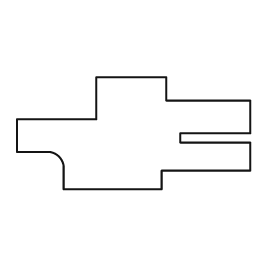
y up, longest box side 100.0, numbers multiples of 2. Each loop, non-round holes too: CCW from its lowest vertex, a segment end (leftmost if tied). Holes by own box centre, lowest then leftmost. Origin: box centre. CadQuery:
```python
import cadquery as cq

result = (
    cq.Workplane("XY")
    .moveTo(-30.0, -24.0)
    .lineTo(12.0, -24.0)
    .lineTo(12.0, -16.0)
    .lineTo(50.0, -16.0)
    .lineTo(50.0, -4.0)
    .lineTo(20.0, -4.0)
    .lineTo(20.0, 0.0)
    .lineTo(50.0, 0.0)
    .lineTo(50.0, 14.0)
    .lineTo(14.0, 14.0)
    .lineTo(14.0, 24.0)
    .lineTo(-16.0, 24.0)
    .lineTo(-16.0, 6.0)
    .lineTo(-50.0, 6.0)
    .lineTo(-50.0, -8.0)
    .lineTo(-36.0, -8.0)
    .threePointArc((-32.0, -10.0), (-30.0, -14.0))
    .close()
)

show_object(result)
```